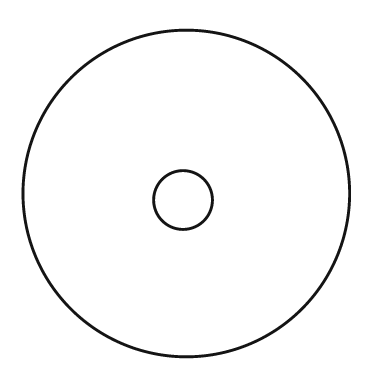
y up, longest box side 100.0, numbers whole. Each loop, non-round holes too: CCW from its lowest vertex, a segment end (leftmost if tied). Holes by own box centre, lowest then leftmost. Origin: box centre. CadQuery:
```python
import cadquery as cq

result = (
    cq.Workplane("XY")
    .moveTo(0.0, 0.0)
    .circle(50.0)
    .moveTo(-1.0, -2.0)
    .circle(9.0)
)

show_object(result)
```